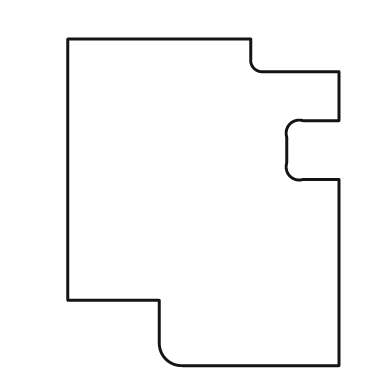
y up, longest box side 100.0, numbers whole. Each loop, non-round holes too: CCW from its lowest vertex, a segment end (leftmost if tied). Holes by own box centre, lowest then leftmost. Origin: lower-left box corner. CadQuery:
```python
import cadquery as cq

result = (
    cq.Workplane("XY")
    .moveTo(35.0, 0.0)
    .lineTo(83.0, 0.0)
    .lineTo(83.0, 57.0)
    .lineTo(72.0, 57.0)
    .threePointArc((68.0, 58.0), (67.0, 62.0))
    .lineTo(67.0, 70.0)
    .threePointArc((68.0, 74.0), (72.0, 75.0))
    .lineTo(83.0, 75.0)
    .lineTo(83.0, 90.0)
    .lineTo(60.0, 90.0)
    .threePointArc((57.0, 91.0), (56.0, 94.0))
    .lineTo(56.0, 100.0)
    .lineTo(0.0, 100.0)
    .lineTo(0.0, 20.0)
    .lineTo(28.0, 20.0)
    .lineTo(28.0, 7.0)
    .threePointArc((30.0, 2.0), (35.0, 0.0))
    .close()
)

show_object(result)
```